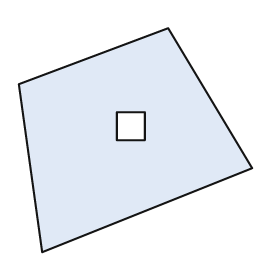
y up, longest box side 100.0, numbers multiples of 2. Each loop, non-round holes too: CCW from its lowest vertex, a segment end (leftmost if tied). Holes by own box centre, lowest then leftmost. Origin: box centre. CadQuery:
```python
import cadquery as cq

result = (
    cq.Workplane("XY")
    .moveTo(-40.0, -48.0)
    .lineTo(50.0, -12.0)
    .lineTo(14.0, 48.0)
    .lineTo(-50.0, 24.0)
    .close()
    .moveTo(-8.0, 0.0)
    .lineTo(4.0, 0.0)
    .lineTo(4.0, 12.0)
    .lineTo(-8.0, 12.0)
    .close()
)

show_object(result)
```